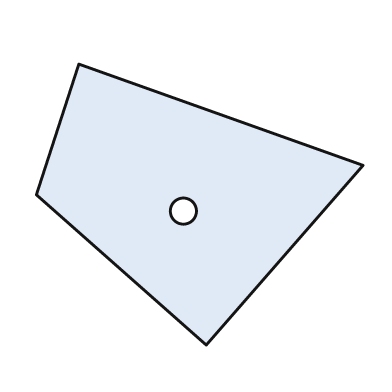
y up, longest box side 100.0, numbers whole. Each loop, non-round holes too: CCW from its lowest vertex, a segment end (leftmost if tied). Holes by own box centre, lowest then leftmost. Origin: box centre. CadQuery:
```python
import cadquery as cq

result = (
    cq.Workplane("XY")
    .moveTo(2.0, -43.0)
    .lineTo(50.0, 12.0)
    .lineTo(-37.0, 43.0)
    .lineTo(-50.0, 3.0)
    .close()
    .moveTo(-5.0, -2.0)
    .circle(4.0)
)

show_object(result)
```